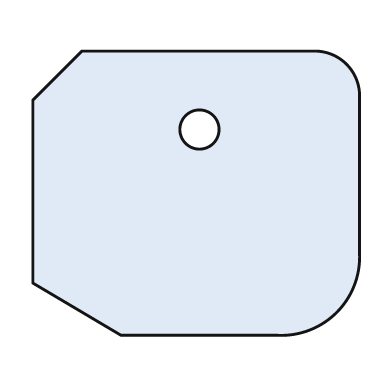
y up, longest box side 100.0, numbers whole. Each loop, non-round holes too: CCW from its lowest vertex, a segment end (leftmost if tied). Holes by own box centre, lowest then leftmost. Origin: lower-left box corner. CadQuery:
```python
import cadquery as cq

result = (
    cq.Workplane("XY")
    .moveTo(27.0, 0.0)
    .lineTo(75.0, 0.0)
    .threePointArc((93.0, 7.0), (100.0, 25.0))
    .lineTo(100.0, 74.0)
    .threePointArc((96.0, 83.0), (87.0, 87.0))
    .lineTo(15.0, 87.0)
    .lineTo(0.0, 72.0)
    .lineTo(0.0, 16.0)
    .close()
    .moveTo(51.0, 63.0)
    .circle(6.0)
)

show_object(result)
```